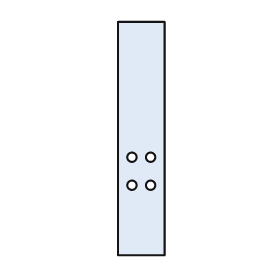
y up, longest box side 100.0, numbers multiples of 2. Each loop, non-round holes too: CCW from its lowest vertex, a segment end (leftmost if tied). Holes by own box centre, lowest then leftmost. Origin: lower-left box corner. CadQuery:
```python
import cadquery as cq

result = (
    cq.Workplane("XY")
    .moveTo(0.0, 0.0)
    .lineTo(20.0, 0.0)
    .lineTo(20.0, 100.0)
    .lineTo(0.0, 100.0)
    .close()
    .moveTo(6.0, 30.0)
    .circle(2.0)
    .moveTo(14.0, 30.0)
    .circle(2.0)
    .moveTo(6.0, 42.0)
    .circle(2.0)
    .moveTo(14.0, 42.0)
    .circle(2.0)
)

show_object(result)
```